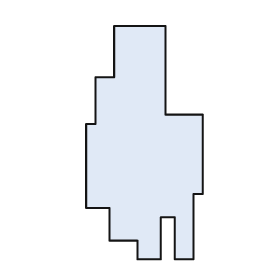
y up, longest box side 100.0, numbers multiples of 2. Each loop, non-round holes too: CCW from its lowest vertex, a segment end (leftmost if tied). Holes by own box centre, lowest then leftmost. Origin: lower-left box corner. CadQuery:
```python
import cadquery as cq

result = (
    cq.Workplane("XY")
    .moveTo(22.0, 0.0)
    .lineTo(32.0, 0.0)
    .lineTo(32.0, 18.0)
    .lineTo(38.0, 18.0)
    .lineTo(38.0, 0.0)
    .lineTo(46.0, 0.0)
    .lineTo(46.0, 28.0)
    .lineTo(50.0, 28.0)
    .lineTo(50.0, 62.0)
    .lineTo(34.0, 62.0)
    .lineTo(34.0, 100.0)
    .lineTo(12.0, 100.0)
    .lineTo(12.0, 78.0)
    .lineTo(4.0, 78.0)
    .lineTo(4.0, 58.0)
    .lineTo(0.0, 58.0)
    .lineTo(0.0, 22.0)
    .lineTo(10.0, 22.0)
    .lineTo(10.0, 8.0)
    .lineTo(22.0, 8.0)
    .close()
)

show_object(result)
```